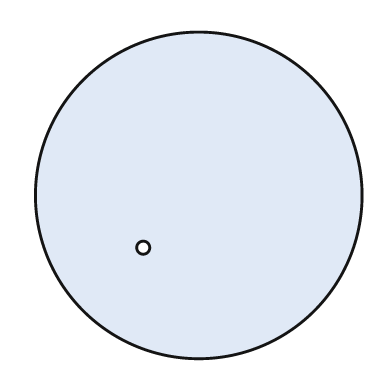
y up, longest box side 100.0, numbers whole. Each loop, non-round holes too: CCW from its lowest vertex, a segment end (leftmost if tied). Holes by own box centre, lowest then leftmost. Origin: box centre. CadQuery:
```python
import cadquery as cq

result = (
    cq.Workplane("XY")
    .moveTo(0.0, 0.0)
    .circle(50.0)
    .moveTo(-17.0, -16.0)
    .circle(2.0)
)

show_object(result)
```